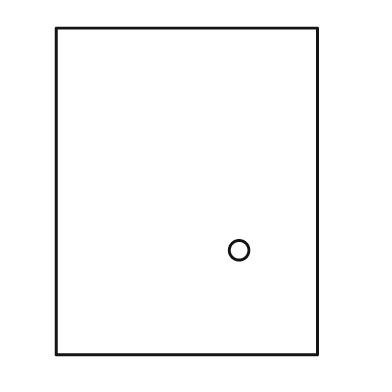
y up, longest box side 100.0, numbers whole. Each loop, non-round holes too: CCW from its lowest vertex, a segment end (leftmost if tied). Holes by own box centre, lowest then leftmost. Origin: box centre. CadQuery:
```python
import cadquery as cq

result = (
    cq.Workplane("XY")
    .moveTo(-40.0, -50.0)
    .lineTo(40.0, -50.0)
    .lineTo(40.0, 50.0)
    .lineTo(-40.0, 50.0)
    .close()
    .moveTo(16.0, -18.0)
    .circle(3.0)
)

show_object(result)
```